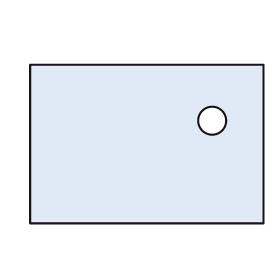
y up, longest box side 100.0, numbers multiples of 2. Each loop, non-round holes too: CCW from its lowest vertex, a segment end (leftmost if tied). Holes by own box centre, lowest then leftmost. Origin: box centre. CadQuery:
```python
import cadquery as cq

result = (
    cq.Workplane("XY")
    .moveTo(-50.0, -34.0)
    .lineTo(50.0, -34.0)
    .lineTo(50.0, 34.0)
    .lineTo(-50.0, 34.0)
    .close()
    .moveTo(28.0, 10.0)
    .circle(6.0)
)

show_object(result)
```